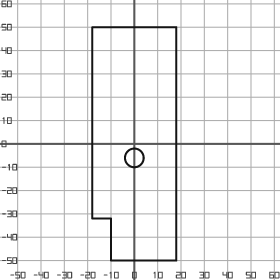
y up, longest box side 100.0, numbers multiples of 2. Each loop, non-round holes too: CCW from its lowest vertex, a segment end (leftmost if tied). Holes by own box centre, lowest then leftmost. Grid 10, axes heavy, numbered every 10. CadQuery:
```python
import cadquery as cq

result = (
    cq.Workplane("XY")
    .moveTo(-10.0, -50.0)
    .lineTo(18.0, -50.0)
    .lineTo(18.0, 50.0)
    .lineTo(-18.0, 50.0)
    .lineTo(-18.0, -32.0)
    .lineTo(-10.0, -32.0)
    .close()
    .moveTo(0.0, -6.0)
    .circle(4.0)
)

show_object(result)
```